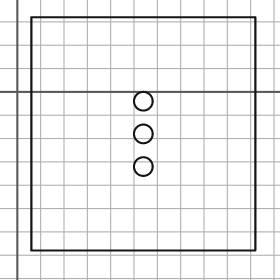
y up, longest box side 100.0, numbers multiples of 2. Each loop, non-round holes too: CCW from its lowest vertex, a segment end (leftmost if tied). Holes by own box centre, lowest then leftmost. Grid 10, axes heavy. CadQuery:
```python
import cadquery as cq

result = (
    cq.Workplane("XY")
    .moveTo(6.0, -68.0)
    .lineTo(102.0, -68.0)
    .lineTo(102.0, 32.0)
    .lineTo(6.0, 32.0)
    .close()
    .moveTo(54.0, -32.0)
    .circle(4.0)
    .moveTo(54.0, -18.0)
    .circle(4.0)
    .moveTo(54.0, -4.0)
    .circle(4.0)
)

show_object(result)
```